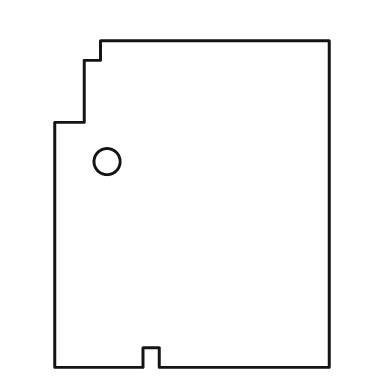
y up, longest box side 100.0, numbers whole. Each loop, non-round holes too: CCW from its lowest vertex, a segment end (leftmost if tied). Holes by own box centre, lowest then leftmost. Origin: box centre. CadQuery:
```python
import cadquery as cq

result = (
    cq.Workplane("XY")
    .moveTo(-42.0, -50.0)
    .lineTo(-15.0, -50.0)
    .lineTo(-15.0, -44.0)
    .lineTo(-10.0, -44.0)
    .lineTo(-10.0, -50.0)
    .lineTo(42.0, -50.0)
    .lineTo(42.0, 50.0)
    .lineTo(-28.0, 50.0)
    .lineTo(-28.0, 44.0)
    .lineTo(-33.0, 44.0)
    .lineTo(-33.0, 25.0)
    .lineTo(-42.0, 25.0)
    .close()
    .moveTo(-26.0, 13.0)
    .circle(4.0)
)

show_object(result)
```